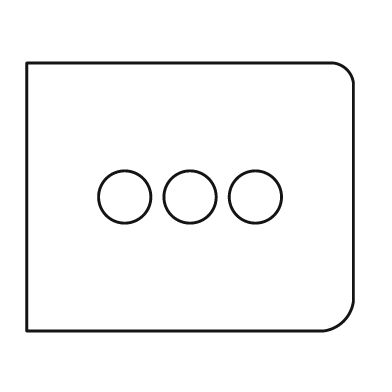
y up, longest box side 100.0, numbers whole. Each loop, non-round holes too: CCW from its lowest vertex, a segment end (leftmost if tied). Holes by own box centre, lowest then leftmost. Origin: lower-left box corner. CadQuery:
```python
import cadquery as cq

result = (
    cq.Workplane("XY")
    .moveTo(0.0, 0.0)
    .lineTo(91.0, 0.0)
    .threePointArc((97.0, 3.0), (100.0, 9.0))
    .lineTo(100.0, 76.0)
    .threePointArc((98.0, 80.0), (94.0, 82.0))
    .lineTo(0.0, 82.0)
    .close()
    .moveTo(30.0, 41.0)
    .circle(8.0)
    .moveTo(50.0, 41.0)
    .circle(8.0)
    .moveTo(70.0, 41.0)
    .circle(8.0)
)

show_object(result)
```